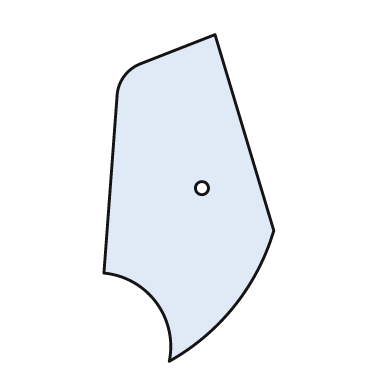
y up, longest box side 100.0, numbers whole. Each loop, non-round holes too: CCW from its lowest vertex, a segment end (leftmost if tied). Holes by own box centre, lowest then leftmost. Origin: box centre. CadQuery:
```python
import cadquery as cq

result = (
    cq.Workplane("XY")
    .moveTo(-6.0, -50.0)
    .threePointArc((14.0, -33.0), (26.0, -10.0))
    .lineTo(8.0, 50.0)
    .lineTo(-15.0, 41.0)
    .threePointArc((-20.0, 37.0), (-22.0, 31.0))
    .lineTo(-26.0, -23.0)
    .threePointArc((-10.0, -32.0), (-6.0, -50.0))
    .close()
    .moveTo(4.0, 3.0)
    .circle(2.0)
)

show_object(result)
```